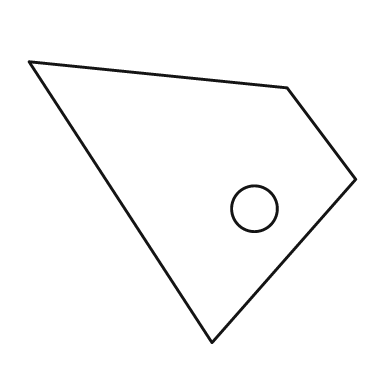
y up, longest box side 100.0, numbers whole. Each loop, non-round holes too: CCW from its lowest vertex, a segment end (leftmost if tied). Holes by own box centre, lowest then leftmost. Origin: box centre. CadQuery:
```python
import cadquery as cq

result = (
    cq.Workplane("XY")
    .moveTo(6.0, -43.0)
    .lineTo(50.0, 7.0)
    .lineTo(29.0, 35.0)
    .lineTo(-50.0, 43.0)
    .close()
    .moveTo(19.0, -2.0)
    .circle(7.0)
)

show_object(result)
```